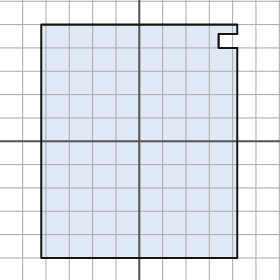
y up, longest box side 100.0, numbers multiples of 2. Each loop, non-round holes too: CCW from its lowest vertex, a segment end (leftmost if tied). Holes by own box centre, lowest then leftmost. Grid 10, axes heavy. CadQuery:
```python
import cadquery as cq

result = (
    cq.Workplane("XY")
    .moveTo(-42.0, -50.0)
    .lineTo(42.0, -50.0)
    .lineTo(42.0, 40.0)
    .lineTo(34.0, 40.0)
    .lineTo(34.0, 46.0)
    .lineTo(42.0, 46.0)
    .lineTo(42.0, 50.0)
    .lineTo(-42.0, 50.0)
    .close()
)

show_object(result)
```